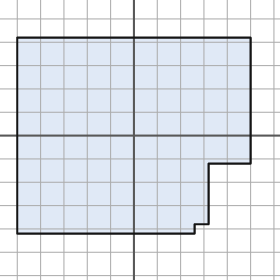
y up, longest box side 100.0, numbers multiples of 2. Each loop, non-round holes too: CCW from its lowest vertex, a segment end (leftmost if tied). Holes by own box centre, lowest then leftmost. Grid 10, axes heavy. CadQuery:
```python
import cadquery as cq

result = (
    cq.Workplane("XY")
    .moveTo(-50.0, -42.0)
    .lineTo(26.0, -42.0)
    .lineTo(26.0, -38.0)
    .lineTo(32.0, -38.0)
    .lineTo(32.0, -12.0)
    .lineTo(50.0, -12.0)
    .lineTo(50.0, 42.0)
    .lineTo(-50.0, 42.0)
    .close()
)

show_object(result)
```